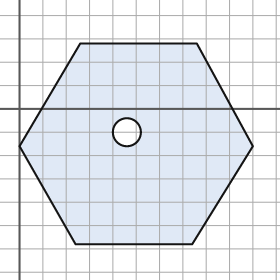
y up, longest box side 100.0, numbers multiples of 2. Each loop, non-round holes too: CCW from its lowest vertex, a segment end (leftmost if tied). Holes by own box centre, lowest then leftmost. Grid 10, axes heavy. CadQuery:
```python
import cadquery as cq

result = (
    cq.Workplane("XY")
    .moveTo(24.0, -58.0)
    .lineTo(74.0, -58.0)
    .lineTo(100.0, -16.0)
    .lineTo(76.0, 28.0)
    .lineTo(26.0, 28.0)
    .lineTo(0.0, -16.0)
    .close()
    .moveTo(46.0, -10.0)
    .circle(6.0)
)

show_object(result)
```